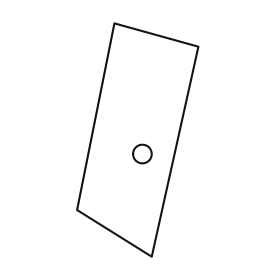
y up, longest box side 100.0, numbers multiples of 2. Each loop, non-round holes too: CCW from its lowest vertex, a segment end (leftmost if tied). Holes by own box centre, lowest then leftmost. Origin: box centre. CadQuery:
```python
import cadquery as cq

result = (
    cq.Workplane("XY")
    .moveTo(6.0, -50.0)
    .lineTo(26.0, 40.0)
    .lineTo(-10.0, 50.0)
    .lineTo(-26.0, -30.0)
    .close()
    .moveTo(2.0, -6.0)
    .circle(4.0)
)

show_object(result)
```